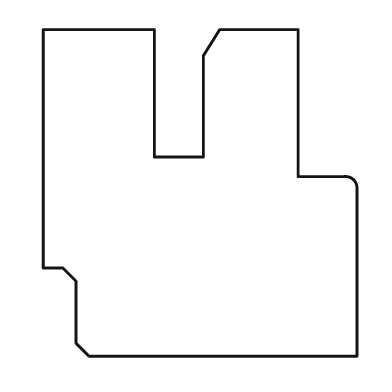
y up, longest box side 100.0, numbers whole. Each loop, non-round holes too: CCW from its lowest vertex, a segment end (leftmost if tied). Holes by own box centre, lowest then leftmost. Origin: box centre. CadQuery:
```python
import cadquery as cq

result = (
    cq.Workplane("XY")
    .moveTo(-34.0, -50.0)
    .lineTo(48.0, -50.0)
    .lineTo(48.0, 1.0)
    .threePointArc((47.0, 4.0), (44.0, 5.0))
    .lineTo(30.0, 5.0)
    .lineTo(30.0, 50.0)
    .lineTo(6.0, 50.0)
    .lineTo(1.0, 42.0)
    .lineTo(1.0, 11.0)
    .lineTo(-14.0, 11.0)
    .lineTo(-14.0, 50.0)
    .lineTo(-48.0, 50.0)
    .lineTo(-48.0, -23.0)
    .lineTo(-42.0, -23.0)
    .lineTo(-38.0, -27.0)
    .lineTo(-38.0, -46.0)
    .close()
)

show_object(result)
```